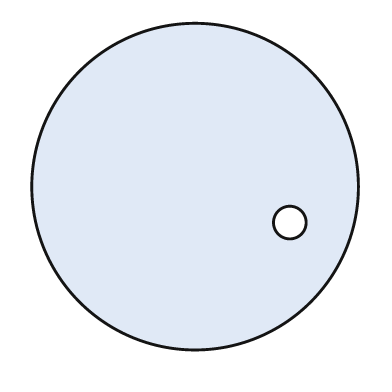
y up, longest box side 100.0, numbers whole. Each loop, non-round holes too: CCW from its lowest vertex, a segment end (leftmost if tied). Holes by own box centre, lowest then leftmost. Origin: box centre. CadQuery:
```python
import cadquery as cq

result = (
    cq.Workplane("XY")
    .moveTo(0.0, 0.0)
    .circle(50.0)
    .moveTo(29.0, -11.0)
    .circle(5.0)
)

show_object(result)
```